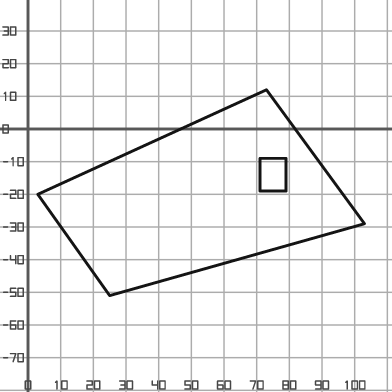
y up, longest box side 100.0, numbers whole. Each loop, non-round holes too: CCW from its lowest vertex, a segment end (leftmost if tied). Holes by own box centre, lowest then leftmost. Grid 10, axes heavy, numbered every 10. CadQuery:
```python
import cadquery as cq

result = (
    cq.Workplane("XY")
    .moveTo(25.0, -51.0)
    .lineTo(103.0, -29.0)
    .lineTo(73.0, 12.0)
    .lineTo(3.0, -20.0)
    .close()
    .moveTo(71.0, -19.0)
    .lineTo(79.0, -19.0)
    .lineTo(79.0, -9.0)
    .lineTo(71.0, -9.0)
    .close()
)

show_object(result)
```